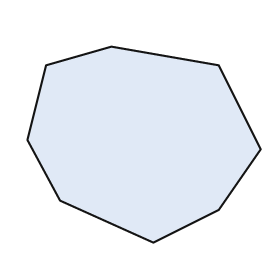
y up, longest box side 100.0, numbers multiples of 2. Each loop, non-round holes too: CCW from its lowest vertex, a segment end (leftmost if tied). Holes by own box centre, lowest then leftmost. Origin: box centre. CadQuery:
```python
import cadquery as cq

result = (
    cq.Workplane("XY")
    .moveTo(4.0, -42.0)
    .lineTo(32.0, -28.0)
    .lineTo(50.0, -2.0)
    .lineTo(32.0, 34.0)
    .lineTo(-14.0, 42.0)
    .lineTo(-42.0, 34.0)
    .lineTo(-50.0, 2.0)
    .lineTo(-36.0, -24.0)
    .close()
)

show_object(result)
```